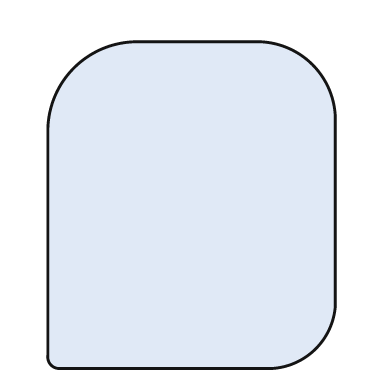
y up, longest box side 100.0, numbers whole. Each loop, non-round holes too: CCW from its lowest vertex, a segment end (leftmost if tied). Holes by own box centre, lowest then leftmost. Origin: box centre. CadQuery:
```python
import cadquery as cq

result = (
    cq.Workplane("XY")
    .moveTo(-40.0, -50.0)
    .lineTo(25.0, -50.0)
    .threePointArc((38.0, -44.0), (44.0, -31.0))
    .lineTo(44.0, 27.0)
    .threePointArc((37.0, 43.0), (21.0, 50.0))
    .lineTo(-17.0, 50.0)
    .threePointArc((-36.0, 42.0), (-44.0, 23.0))
    .lineTo(-44.0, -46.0)
    .threePointArc((-43.0, -49.0), (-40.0, -50.0))
    .close()
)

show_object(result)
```